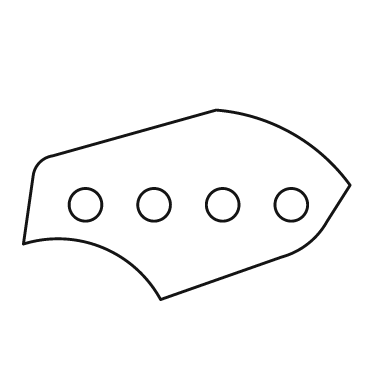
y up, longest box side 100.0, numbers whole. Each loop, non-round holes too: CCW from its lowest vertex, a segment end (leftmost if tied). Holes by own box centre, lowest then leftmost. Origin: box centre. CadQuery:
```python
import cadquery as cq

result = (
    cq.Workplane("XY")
    .moveTo(-8.0, -29.0)
    .lineTo(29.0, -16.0)
    .threePointArc((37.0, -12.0), (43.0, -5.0))
    .lineTo(50.0, 6.0)
    .threePointArc((32.0, 22.0), (9.0, 29.0))
    .lineTo(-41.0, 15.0)
    .threePointArc((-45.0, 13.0), (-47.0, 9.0))
    .lineTo(-50.0, -12.0)
    .threePointArc((-26.0, -13.0), (-8.0, -29.0))
    .close()
    .moveTo(-31.0, 0.0)
    .circle(5.0)
    .moveTo(-10.0, 0.0)
    .circle(5.0)
    .moveTo(11.0, 0.0)
    .circle(5.0)
    .moveTo(32.0, 0.0)
    .circle(5.0)
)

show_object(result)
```